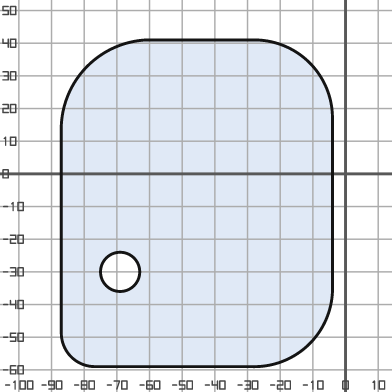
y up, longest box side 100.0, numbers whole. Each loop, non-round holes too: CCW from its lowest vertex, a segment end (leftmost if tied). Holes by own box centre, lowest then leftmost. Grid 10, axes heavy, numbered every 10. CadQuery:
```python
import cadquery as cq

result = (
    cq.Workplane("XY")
    .moveTo(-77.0, -59.0)
    .lineTo(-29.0, -59.0)
    .threePointArc((-11.0, -52.0), (-4.0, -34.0))
    .lineTo(-4.0, 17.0)
    .threePointArc((-11.0, 34.0), (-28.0, 41.0))
    .lineTo(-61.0, 41.0)
    .threePointArc((-79.0, 33.0), (-87.0, 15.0))
    .lineTo(-87.0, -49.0)
    .threePointArc((-84.0, -56.0), (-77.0, -59.0))
    .close()
    .moveTo(-69.0, -30.0)
    .circle(6.0)
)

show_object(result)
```